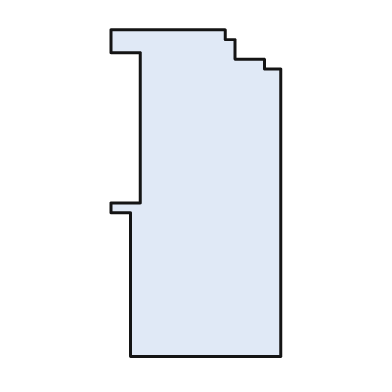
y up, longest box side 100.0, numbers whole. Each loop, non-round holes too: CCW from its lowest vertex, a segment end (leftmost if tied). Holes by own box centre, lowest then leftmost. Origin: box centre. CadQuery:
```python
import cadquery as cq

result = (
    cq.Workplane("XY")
    .moveTo(-20.0, -50.0)
    .lineTo(26.0, -50.0)
    .lineTo(26.0, 38.0)
    .lineTo(21.0, 38.0)
    .lineTo(21.0, 41.0)
    .lineTo(12.0, 41.0)
    .lineTo(12.0, 47.0)
    .lineTo(9.0, 47.0)
    .lineTo(9.0, 50.0)
    .lineTo(-26.0, 50.0)
    .lineTo(-26.0, 43.0)
    .lineTo(-17.0, 43.0)
    .lineTo(-17.0, -3.0)
    .lineTo(-26.0, -3.0)
    .lineTo(-26.0, -6.0)
    .lineTo(-20.0, -6.0)
    .close()
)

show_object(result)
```